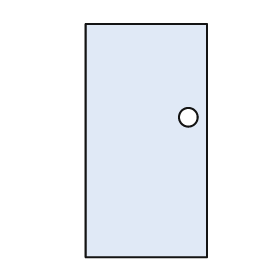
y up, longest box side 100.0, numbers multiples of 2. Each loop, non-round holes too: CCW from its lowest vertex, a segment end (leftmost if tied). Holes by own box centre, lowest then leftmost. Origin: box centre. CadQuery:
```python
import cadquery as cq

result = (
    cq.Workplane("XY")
    .moveTo(-26.0, -50.0)
    .lineTo(26.0, -50.0)
    .lineTo(26.0, 50.0)
    .lineTo(-26.0, 50.0)
    .close()
    .moveTo(18.0, 10.0)
    .circle(4.0)
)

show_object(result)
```